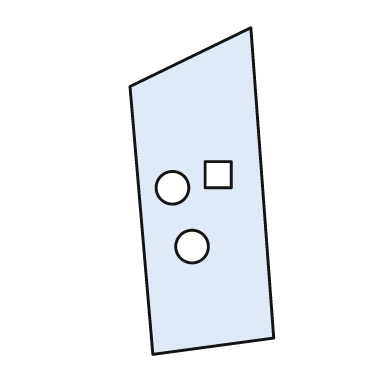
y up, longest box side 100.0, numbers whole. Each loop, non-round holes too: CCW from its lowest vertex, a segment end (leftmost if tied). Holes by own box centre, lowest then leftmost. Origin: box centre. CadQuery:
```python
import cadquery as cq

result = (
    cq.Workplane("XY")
    .moveTo(-15.0, -50.0)
    .lineTo(22.0, -45.0)
    .lineTo(15.0, 50.0)
    .lineTo(-22.0, 32.0)
    .close()
    .moveTo(-3.0, -17.0)
    .circle(5.0)
    .moveTo(-9.0, 1.0)
    .circle(5.0)
    .moveTo(1.0, 1.0)
    .lineTo(9.0, 1.0)
    .lineTo(9.0, 9.0)
    .lineTo(1.0, 9.0)
    .close()
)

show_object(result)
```